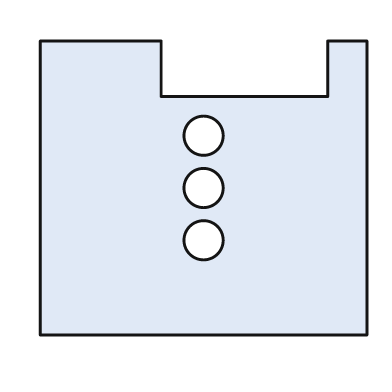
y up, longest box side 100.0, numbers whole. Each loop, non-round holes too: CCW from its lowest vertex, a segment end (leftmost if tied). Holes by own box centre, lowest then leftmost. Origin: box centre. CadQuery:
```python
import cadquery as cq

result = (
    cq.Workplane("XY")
    .moveTo(-50.0, -45.0)
    .lineTo(50.0, -45.0)
    .lineTo(50.0, 45.0)
    .lineTo(38.0, 45.0)
    .lineTo(38.0, 28.0)
    .lineTo(-13.0, 28.0)
    .lineTo(-13.0, 45.0)
    .lineTo(-50.0, 45.0)
    .close()
    .moveTo(0.0, -16.0)
    .circle(6.0)
    .moveTo(0.0, 0.0)
    .circle(6.0)
    .moveTo(0.0, 16.0)
    .circle(6.0)
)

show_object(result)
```